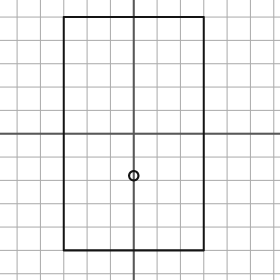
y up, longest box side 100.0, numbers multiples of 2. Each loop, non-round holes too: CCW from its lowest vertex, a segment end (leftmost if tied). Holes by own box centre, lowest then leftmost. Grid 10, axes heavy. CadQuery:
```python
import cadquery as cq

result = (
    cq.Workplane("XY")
    .moveTo(-30.0, -50.0)
    .lineTo(30.0, -50.0)
    .lineTo(30.0, 50.0)
    .lineTo(-30.0, 50.0)
    .close()
    .moveTo(0.0, -18.0)
    .circle(2.0)
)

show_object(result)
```